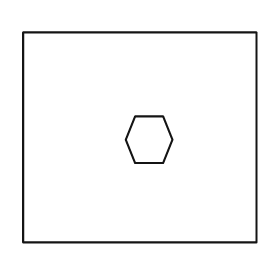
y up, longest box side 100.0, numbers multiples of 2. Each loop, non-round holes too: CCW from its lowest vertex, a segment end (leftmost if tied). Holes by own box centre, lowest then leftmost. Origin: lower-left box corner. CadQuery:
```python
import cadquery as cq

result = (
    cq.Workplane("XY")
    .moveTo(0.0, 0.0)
    .lineTo(100.0, 0.0)
    .lineTo(100.0, 90.0)
    .lineTo(0.0, 90.0)
    .close()
    .moveTo(48.0, 34.0)
    .lineTo(60.0, 34.0)
    .lineTo(64.0, 44.0)
    .lineTo(60.0, 54.0)
    .lineTo(48.0, 54.0)
    .lineTo(44.0, 44.0)
    .close()
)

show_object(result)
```